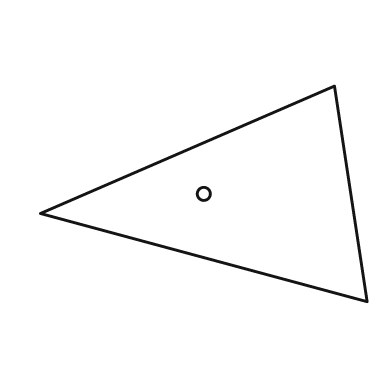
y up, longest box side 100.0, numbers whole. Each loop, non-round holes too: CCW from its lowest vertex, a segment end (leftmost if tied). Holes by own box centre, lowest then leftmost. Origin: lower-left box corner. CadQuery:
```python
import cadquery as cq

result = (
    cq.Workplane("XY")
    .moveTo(100.0, 0.0)
    .lineTo(90.0, 66.0)
    .lineTo(0.0, 27.0)
    .close()
    .moveTo(50.0, 33.0)
    .circle(2.0)
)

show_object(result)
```